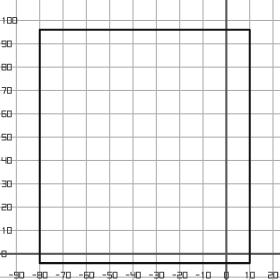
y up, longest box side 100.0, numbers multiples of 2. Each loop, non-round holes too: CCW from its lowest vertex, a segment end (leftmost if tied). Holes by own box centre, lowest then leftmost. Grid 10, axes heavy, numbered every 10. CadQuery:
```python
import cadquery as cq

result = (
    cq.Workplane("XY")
    .moveTo(-80.0, -4.0)
    .lineTo(10.0, -4.0)
    .lineTo(10.0, 96.0)
    .lineTo(-80.0, 96.0)
    .close()
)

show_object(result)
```